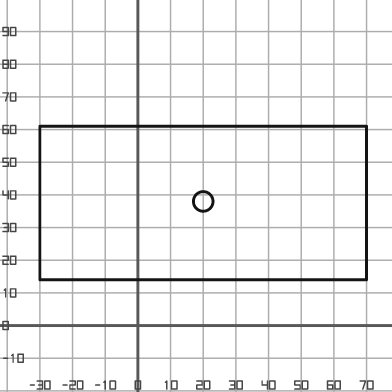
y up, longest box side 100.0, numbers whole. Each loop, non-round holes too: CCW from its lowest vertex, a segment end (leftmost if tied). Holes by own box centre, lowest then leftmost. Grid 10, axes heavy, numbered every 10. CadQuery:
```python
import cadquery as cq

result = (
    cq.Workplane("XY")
    .moveTo(-30.0, 14.0)
    .lineTo(70.0, 14.0)
    .lineTo(70.0, 61.0)
    .lineTo(-30.0, 61.0)
    .close()
    .moveTo(20.0, 38.0)
    .circle(3.0)
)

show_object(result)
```